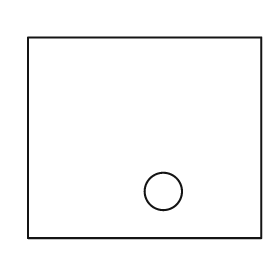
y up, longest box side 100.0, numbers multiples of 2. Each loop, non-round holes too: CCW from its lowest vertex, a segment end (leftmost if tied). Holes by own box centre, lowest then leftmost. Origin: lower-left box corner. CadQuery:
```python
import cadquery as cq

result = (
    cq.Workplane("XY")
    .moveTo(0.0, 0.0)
    .lineTo(100.0, 0.0)
    .lineTo(100.0, 86.0)
    .lineTo(0.0, 86.0)
    .close()
    .moveTo(58.0, 20.0)
    .circle(8.0)
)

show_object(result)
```